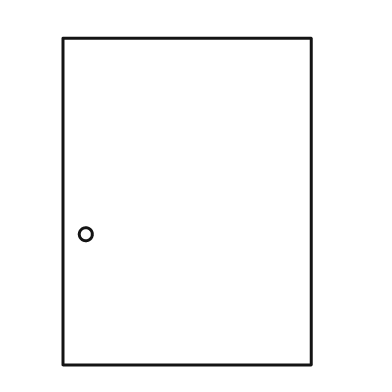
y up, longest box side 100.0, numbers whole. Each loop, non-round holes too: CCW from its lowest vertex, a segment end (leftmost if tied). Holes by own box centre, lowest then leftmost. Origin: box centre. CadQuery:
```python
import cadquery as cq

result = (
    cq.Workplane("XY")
    .moveTo(-38.0, -50.0)
    .lineTo(38.0, -50.0)
    .lineTo(38.0, 50.0)
    .lineTo(-38.0, 50.0)
    .close()
    .moveTo(-31.0, -10.0)
    .circle(2.0)
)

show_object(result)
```